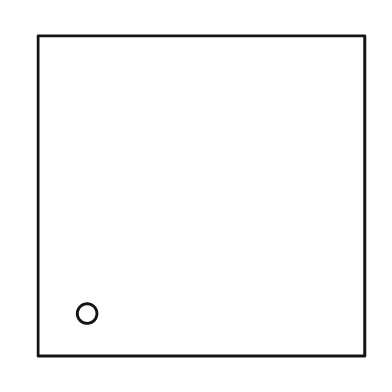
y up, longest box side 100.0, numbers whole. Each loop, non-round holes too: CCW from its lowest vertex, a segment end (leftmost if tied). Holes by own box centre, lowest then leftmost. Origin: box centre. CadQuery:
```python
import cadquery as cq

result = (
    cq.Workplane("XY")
    .moveTo(-50.0, -49.0)
    .lineTo(50.0, -49.0)
    .lineTo(50.0, 49.0)
    .lineTo(-50.0, 49.0)
    .close()
    .moveTo(-35.0, -36.0)
    .circle(3.0)
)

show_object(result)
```